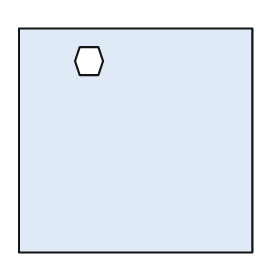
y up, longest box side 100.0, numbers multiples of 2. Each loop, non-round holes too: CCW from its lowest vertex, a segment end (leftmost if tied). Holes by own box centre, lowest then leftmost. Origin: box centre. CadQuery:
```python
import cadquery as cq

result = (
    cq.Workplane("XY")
    .moveTo(-50.0, -48.0)
    .lineTo(50.0, -48.0)
    .lineTo(50.0, 48.0)
    .lineTo(-50.0, 48.0)
    .close()
    .moveTo(-24.0, 28.0)
    .lineTo(-16.0, 28.0)
    .lineTo(-14.0, 34.0)
    .lineTo(-16.0, 40.0)
    .lineTo(-24.0, 40.0)
    .lineTo(-26.0, 34.0)
    .close()
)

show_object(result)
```